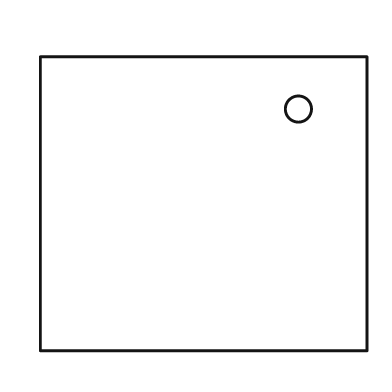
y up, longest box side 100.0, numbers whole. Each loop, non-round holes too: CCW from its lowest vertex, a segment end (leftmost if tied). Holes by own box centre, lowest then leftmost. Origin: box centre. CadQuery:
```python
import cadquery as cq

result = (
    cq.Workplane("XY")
    .moveTo(-50.0, -45.0)
    .lineTo(50.0, -45.0)
    .lineTo(50.0, 45.0)
    .lineTo(-50.0, 45.0)
    .close()
    .moveTo(29.0, 29.0)
    .circle(4.0)
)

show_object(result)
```